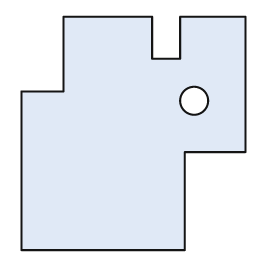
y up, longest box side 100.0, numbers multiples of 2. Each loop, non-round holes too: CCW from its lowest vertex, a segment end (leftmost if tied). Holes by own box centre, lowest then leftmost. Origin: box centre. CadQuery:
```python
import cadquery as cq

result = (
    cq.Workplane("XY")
    .moveTo(-48.0, -50.0)
    .lineTo(22.0, -50.0)
    .lineTo(22.0, -8.0)
    .lineTo(48.0, -8.0)
    .lineTo(48.0, 50.0)
    .lineTo(20.0, 50.0)
    .lineTo(20.0, 32.0)
    .lineTo(8.0, 32.0)
    .lineTo(8.0, 50.0)
    .lineTo(-30.0, 50.0)
    .lineTo(-30.0, 18.0)
    .lineTo(-48.0, 18.0)
    .close()
    .moveTo(26.0, 14.0)
    .circle(6.0)
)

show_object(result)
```